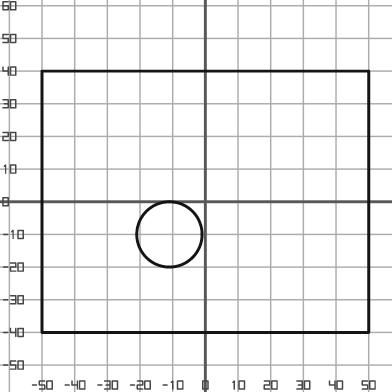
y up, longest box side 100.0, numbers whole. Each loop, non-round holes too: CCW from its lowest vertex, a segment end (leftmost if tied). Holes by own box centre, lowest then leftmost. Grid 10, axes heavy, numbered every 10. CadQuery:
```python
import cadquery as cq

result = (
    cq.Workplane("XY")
    .moveTo(-50.0, -40.0)
    .lineTo(50.0, -40.0)
    .lineTo(50.0, 40.0)
    .lineTo(-50.0, 40.0)
    .close()
    .moveTo(-11.0, -10.0)
    .circle(10.0)
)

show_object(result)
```